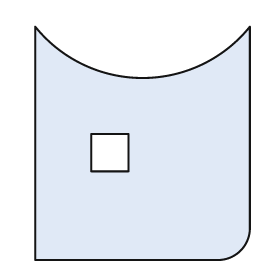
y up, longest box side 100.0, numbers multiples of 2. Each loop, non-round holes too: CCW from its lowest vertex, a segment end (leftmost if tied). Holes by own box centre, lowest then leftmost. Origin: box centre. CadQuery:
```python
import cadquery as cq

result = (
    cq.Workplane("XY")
    .moveTo(-46.0, -50.0)
    .lineTo(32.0, -50.0)
    .threePointArc((42.0, -46.0), (46.0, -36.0))
    .lineTo(46.0, 50.0)
    .threePointArc((0.0, 28.0), (-46.0, 50.0))
    .close()
    .moveTo(-22.0, -12.0)
    .lineTo(-6.0, -12.0)
    .lineTo(-6.0, 4.0)
    .lineTo(-22.0, 4.0)
    .close()
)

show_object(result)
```